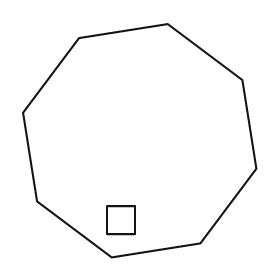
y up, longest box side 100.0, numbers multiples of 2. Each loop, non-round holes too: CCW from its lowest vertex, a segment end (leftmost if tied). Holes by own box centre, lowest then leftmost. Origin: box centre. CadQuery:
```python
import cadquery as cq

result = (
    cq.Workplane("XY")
    .moveTo(-12.0, -50.0)
    .lineTo(26.0, -44.0)
    .lineTo(50.0, -12.0)
    .lineTo(44.0, 26.0)
    .lineTo(12.0, 50.0)
    .lineTo(-26.0, 44.0)
    .lineTo(-50.0, 12.0)
    .lineTo(-44.0, -26.0)
    .close()
    .moveTo(-14.0, -40.0)
    .lineTo(-2.0, -40.0)
    .lineTo(-2.0, -28.0)
    .lineTo(-14.0, -28.0)
    .close()
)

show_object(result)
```